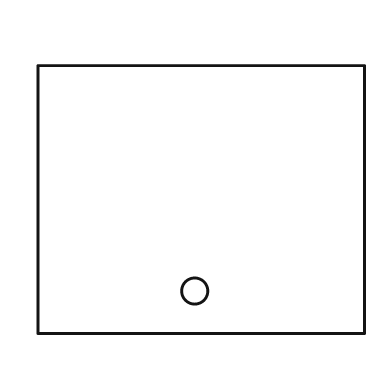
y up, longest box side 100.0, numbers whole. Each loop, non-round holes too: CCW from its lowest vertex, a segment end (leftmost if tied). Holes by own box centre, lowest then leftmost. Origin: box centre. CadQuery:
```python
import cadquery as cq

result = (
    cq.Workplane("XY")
    .moveTo(-50.0, -41.0)
    .lineTo(50.0, -41.0)
    .lineTo(50.0, 41.0)
    .lineTo(-50.0, 41.0)
    .close()
    .moveTo(-2.0, -28.0)
    .circle(4.0)
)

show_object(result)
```